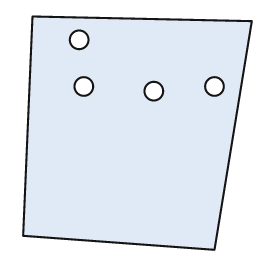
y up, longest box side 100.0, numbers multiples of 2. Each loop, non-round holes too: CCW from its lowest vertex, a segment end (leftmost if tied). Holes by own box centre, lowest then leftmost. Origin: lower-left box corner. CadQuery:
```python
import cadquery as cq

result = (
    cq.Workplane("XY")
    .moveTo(82.0, 0.0)
    .lineTo(98.0, 98.0)
    .lineTo(4.0, 100.0)
    .lineTo(0.0, 6.0)
    .close()
    .moveTo(56.0, 68.0)
    .circle(4.0)
    .moveTo(26.0, 70.0)
    .circle(4.0)
    .moveTo(82.0, 70.0)
    .circle(4.0)
    .moveTo(24.0, 90.0)
    .circle(4.0)
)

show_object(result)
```